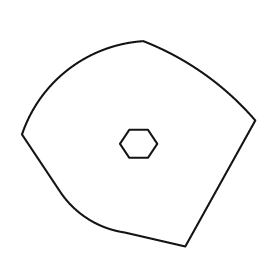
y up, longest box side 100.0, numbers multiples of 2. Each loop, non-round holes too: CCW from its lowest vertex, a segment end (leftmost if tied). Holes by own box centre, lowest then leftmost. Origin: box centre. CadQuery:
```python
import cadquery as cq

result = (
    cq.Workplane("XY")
    .moveTo(20.0, -44.0)
    .lineTo(50.0, 10.0)
    .threePointArc((28.0, 30.0), (2.0, 44.0))
    .threePointArc((-30.0, 32.0), (-50.0, 4.0))
    .lineTo(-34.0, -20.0)
    .threePointArc((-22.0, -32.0), (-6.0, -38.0))
    .close()
    .moveTo(-4.0, -6.0)
    .lineTo(4.0, -6.0)
    .lineTo(8.0, 0.0)
    .lineTo(4.0, 6.0)
    .lineTo(-4.0, 6.0)
    .lineTo(-8.0, 0.0)
    .close()
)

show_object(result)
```